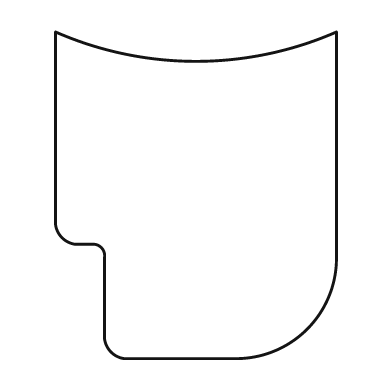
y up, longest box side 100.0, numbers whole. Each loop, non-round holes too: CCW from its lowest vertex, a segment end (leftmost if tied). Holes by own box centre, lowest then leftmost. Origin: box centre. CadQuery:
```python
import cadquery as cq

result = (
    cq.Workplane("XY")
    .moveTo(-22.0, -50.0)
    .lineTo(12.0, -50.0)
    .threePointArc((34.0, -41.0), (43.0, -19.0))
    .lineTo(43.0, 50.0)
    .threePointArc((0.0, 41.0), (-43.0, 50.0))
    .lineTo(-43.0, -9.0)
    .threePointArc((-41.0, -13.0), (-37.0, -15.0))
    .lineTo(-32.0, -15.0)
    .threePointArc((-29.0, -16.0), (-28.0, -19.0))
    .lineTo(-28.0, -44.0)
    .threePointArc((-26.0, -48.0), (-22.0, -50.0))
    .close()
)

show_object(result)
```